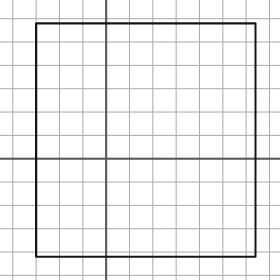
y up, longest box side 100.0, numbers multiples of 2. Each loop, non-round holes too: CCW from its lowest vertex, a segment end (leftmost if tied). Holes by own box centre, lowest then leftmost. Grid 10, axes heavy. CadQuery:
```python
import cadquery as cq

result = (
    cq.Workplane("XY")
    .moveTo(-30.0, -42.0)
    .lineTo(64.0, -42.0)
    .lineTo(64.0, 58.0)
    .lineTo(-30.0, 58.0)
    .close()
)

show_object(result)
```